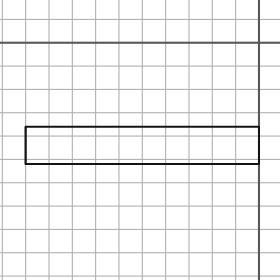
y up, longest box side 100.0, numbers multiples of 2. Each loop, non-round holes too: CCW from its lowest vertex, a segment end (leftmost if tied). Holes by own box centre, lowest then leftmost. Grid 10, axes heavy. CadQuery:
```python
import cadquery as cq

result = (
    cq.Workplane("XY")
    .moveTo(-100.0, -52.0)
    .lineTo(0.0, -52.0)
    .lineTo(0.0, -36.0)
    .lineTo(-100.0, -36.0)
    .close()
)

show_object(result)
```